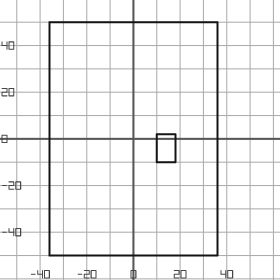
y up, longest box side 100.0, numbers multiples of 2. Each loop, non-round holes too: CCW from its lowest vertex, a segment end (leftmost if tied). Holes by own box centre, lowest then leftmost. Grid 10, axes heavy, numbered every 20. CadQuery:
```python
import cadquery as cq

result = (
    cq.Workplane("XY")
    .moveTo(-36.0, -50.0)
    .lineTo(36.0, -50.0)
    .lineTo(36.0, 50.0)
    .lineTo(-36.0, 50.0)
    .close()
    .moveTo(10.0, -10.0)
    .lineTo(18.0, -10.0)
    .lineTo(18.0, 2.0)
    .lineTo(10.0, 2.0)
    .close()
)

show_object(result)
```